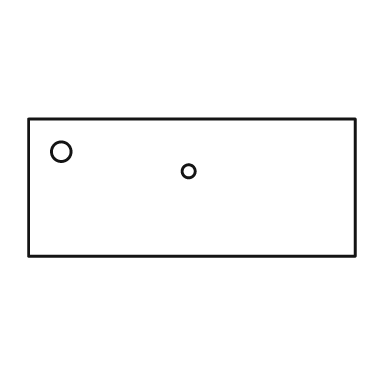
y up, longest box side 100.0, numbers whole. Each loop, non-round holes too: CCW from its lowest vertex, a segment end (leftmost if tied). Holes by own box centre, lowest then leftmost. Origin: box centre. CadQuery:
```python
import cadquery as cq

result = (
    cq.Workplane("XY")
    .moveTo(-50.0, -21.0)
    .lineTo(50.0, -21.0)
    .lineTo(50.0, 21.0)
    .lineTo(-50.0, 21.0)
    .close()
    .moveTo(-1.0, 5.0)
    .circle(2.0)
    .moveTo(-40.0, 11.0)
    .circle(3.0)
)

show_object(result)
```